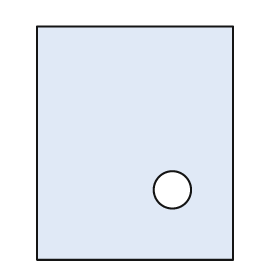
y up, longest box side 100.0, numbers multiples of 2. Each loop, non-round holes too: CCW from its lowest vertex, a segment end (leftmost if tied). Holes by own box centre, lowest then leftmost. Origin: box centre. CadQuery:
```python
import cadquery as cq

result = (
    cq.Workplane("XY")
    .moveTo(-42.0, -50.0)
    .lineTo(42.0, -50.0)
    .lineTo(42.0, 50.0)
    .lineTo(-42.0, 50.0)
    .close()
    .moveTo(16.0, -20.0)
    .circle(8.0)
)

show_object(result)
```